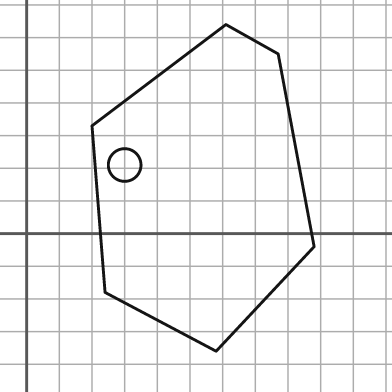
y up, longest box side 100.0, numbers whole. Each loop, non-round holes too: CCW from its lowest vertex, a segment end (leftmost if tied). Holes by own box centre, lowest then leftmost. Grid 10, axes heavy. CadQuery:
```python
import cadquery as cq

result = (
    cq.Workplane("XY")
    .moveTo(58.0, -36.0)
    .lineTo(88.0, -4.0)
    .lineTo(77.0, 55.0)
    .lineTo(61.0, 64.0)
    .lineTo(20.0, 33.0)
    .lineTo(24.0, -18.0)
    .close()
    .moveTo(30.0, 21.0)
    .circle(5.0)
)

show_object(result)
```